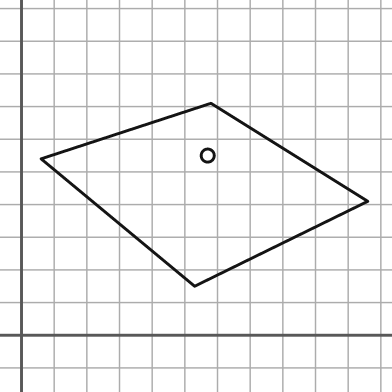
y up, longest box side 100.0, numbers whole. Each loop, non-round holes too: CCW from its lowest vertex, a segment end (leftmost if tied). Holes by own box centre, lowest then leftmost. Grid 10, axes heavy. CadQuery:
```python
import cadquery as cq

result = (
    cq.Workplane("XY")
    .moveTo(53.0, 15.0)
    .lineTo(106.0, 41.0)
    .lineTo(58.0, 71.0)
    .lineTo(6.0, 54.0)
    .close()
    .moveTo(57.0, 55.0)
    .circle(2.0)
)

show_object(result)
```